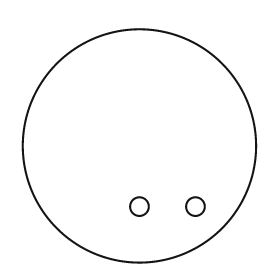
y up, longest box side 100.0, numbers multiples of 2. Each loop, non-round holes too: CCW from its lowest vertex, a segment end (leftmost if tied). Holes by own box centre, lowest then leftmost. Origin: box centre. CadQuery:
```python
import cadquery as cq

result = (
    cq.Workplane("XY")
    .moveTo(0.0, 0.0)
    .circle(50.0)
    .moveTo(0.0, -26.0)
    .circle(4.0)
    .moveTo(24.0, -26.0)
    .circle(4.0)
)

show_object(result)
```